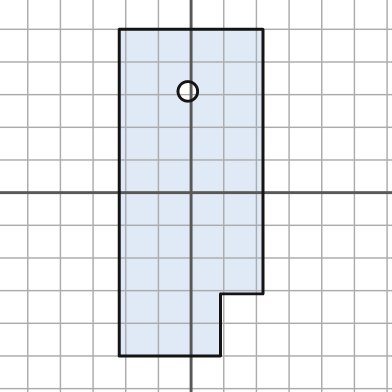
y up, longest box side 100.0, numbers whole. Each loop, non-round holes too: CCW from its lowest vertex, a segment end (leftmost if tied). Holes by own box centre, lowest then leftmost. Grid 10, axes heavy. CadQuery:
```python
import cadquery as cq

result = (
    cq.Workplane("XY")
    .moveTo(-22.0, -50.0)
    .lineTo(9.0, -50.0)
    .lineTo(9.0, -31.0)
    .lineTo(22.0, -31.0)
    .lineTo(22.0, 50.0)
    .lineTo(-22.0, 50.0)
    .close()
    .moveTo(-1.0, 31.0)
    .circle(3.0)
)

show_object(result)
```